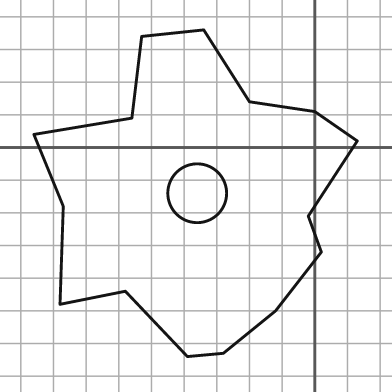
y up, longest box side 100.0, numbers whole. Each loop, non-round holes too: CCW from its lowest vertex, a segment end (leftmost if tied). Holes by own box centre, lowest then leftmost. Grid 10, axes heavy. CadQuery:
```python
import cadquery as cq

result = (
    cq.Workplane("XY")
    .moveTo(-39.0, -64.0)
    .lineTo(-28.0, -63.0)
    .lineTo(-12.0, -50.0)
    .lineTo(2.0, -32.0)
    .lineTo(-2.0, -21.0)
    .lineTo(13.0, 2.0)
    .lineTo(0.0, 11.0)
    .lineTo(-20.0, 14.0)
    .lineTo(-34.0, 36.0)
    .lineTo(-53.0, 34.0)
    .lineTo(-56.0, 9.0)
    .lineTo(-86.0, 4.0)
    .lineTo(-77.0, -18.0)
    .lineTo(-78.0, -48.0)
    .lineTo(-58.0, -44.0)
    .close()
    .moveTo(-36.0, -14.0)
    .circle(9.0)
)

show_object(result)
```